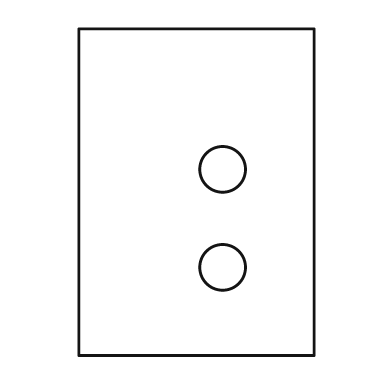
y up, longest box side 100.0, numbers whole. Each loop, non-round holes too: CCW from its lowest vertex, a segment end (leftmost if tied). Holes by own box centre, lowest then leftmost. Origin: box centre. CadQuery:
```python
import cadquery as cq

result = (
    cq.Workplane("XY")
    .moveTo(-36.0, -50.0)
    .lineTo(36.0, -50.0)
    .lineTo(36.0, 50.0)
    .lineTo(-36.0, 50.0)
    .close()
    .moveTo(8.0, -23.0)
    .circle(7.0)
    .moveTo(8.0, 7.0)
    .circle(7.0)
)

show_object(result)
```